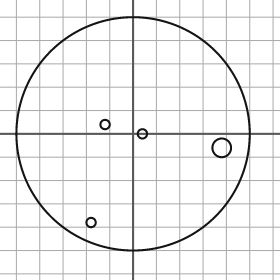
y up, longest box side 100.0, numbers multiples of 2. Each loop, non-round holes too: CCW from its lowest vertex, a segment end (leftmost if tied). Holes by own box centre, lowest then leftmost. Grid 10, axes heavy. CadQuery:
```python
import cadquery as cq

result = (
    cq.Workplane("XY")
    .moveTo(0.0, 0.0)
    .circle(50.0)
    .moveTo(-18.0, -38.0)
    .circle(2.0)
    .moveTo(38.0, -6.0)
    .circle(4.0)
    .moveTo(4.0, 0.0)
    .circle(2.0)
    .moveTo(-12.0, 4.0)
    .circle(2.0)
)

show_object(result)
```